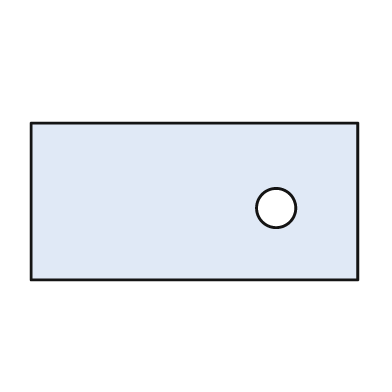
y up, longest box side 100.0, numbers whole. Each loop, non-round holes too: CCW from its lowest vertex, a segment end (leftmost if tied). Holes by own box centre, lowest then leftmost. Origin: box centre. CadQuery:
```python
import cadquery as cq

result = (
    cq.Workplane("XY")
    .moveTo(-50.0, -24.0)
    .lineTo(50.0, -24.0)
    .lineTo(50.0, 24.0)
    .lineTo(-50.0, 24.0)
    .close()
    .moveTo(25.0, -2.0)
    .circle(6.0)
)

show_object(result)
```